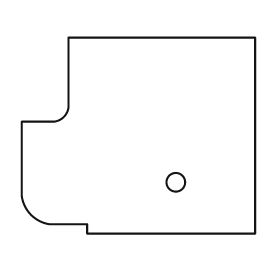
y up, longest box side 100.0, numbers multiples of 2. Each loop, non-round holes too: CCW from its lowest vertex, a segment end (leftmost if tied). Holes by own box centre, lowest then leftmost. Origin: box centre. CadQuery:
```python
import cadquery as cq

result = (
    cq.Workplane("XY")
    .moveTo(-22.0, -42.0)
    .lineTo(50.0, -42.0)
    .lineTo(50.0, 42.0)
    .lineTo(-30.0, 42.0)
    .lineTo(-30.0, 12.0)
    .threePointArc((-32.0, 8.0), (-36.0, 6.0))
    .lineTo(-50.0, 6.0)
    .lineTo(-50.0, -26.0)
    .threePointArc((-46.0, -34.0), (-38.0, -38.0))
    .lineTo(-22.0, -38.0)
    .close()
    .moveTo(16.0, -20.0)
    .circle(4.0)
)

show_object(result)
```